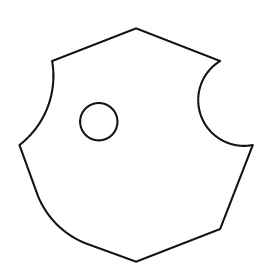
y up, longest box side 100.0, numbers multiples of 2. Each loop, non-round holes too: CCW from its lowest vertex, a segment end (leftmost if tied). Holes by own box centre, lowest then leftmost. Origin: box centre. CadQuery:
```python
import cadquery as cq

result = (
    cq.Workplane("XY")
    .moveTo(0.0, -50.0)
    .lineTo(36.0, -36.0)
    .lineTo(50.0, 0.0)
    .threePointArc((28.0, 12.0), (36.0, 36.0))
    .lineTo(0.0, 50.0)
    .lineTo(-36.0, 36.0)
    .threePointArc((-38.0, 16.0), (-50.0, 0.0))
    .lineTo(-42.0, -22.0)
    .threePointArc((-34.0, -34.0), (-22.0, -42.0))
    .close()
    .moveTo(-16.0, 10.0)
    .circle(8.0)
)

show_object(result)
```